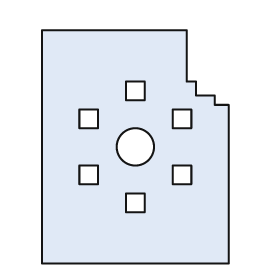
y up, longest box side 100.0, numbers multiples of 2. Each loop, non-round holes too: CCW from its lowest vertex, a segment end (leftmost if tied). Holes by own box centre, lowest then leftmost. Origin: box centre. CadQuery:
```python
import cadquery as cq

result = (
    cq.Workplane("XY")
    .moveTo(-40.0, -50.0)
    .lineTo(40.0, -50.0)
    .lineTo(40.0, 18.0)
    .lineTo(34.0, 18.0)
    .lineTo(34.0, 22.0)
    .lineTo(26.0, 22.0)
    .lineTo(26.0, 28.0)
    .lineTo(22.0, 28.0)
    .lineTo(22.0, 50.0)
    .lineTo(-40.0, 50.0)
    .close()
    .moveTo(-4.0, -28.0)
    .lineTo(4.0, -28.0)
    .lineTo(4.0, -20.0)
    .lineTo(-4.0, -20.0)
    .close()
    .moveTo(-24.0, -16.0)
    .lineTo(-16.0, -16.0)
    .lineTo(-16.0, -8.0)
    .lineTo(-24.0, -8.0)
    .close()
    .moveTo(16.0, -16.0)
    .lineTo(24.0, -16.0)
    .lineTo(24.0, -8.0)
    .lineTo(16.0, -8.0)
    .close()
    .moveTo(0.0, 0.0)
    .circle(8.0)
    .moveTo(-24.0, 8.0)
    .lineTo(-16.0, 8.0)
    .lineTo(-16.0, 16.0)
    .lineTo(-24.0, 16.0)
    .close()
    .moveTo(16.0, 8.0)
    .lineTo(24.0, 8.0)
    .lineTo(24.0, 16.0)
    .lineTo(16.0, 16.0)
    .close()
    .moveTo(-4.0, 20.0)
    .lineTo(4.0, 20.0)
    .lineTo(4.0, 28.0)
    .lineTo(-4.0, 28.0)
    .close()
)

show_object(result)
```